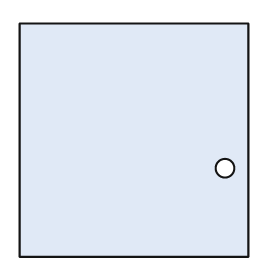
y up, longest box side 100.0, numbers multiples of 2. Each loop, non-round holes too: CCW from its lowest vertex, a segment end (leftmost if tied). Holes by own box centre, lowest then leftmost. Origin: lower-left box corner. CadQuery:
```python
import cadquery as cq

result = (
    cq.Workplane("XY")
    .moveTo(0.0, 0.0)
    .lineTo(98.0, 0.0)
    .lineTo(98.0, 100.0)
    .lineTo(0.0, 100.0)
    .close()
    .moveTo(88.0, 38.0)
    .circle(4.0)
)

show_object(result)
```